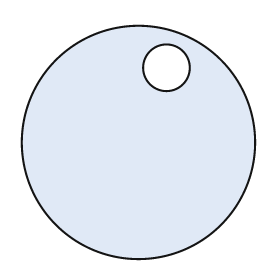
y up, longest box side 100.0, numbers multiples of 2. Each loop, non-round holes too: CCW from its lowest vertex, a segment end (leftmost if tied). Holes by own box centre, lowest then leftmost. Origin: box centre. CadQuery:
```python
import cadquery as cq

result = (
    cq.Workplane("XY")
    .moveTo(0.0, 0.0)
    .circle(50.0)
    .moveTo(12.0, 32.0)
    .circle(10.0)
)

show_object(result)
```